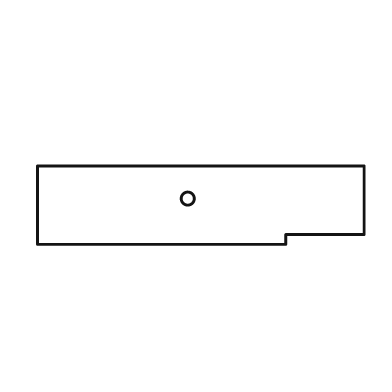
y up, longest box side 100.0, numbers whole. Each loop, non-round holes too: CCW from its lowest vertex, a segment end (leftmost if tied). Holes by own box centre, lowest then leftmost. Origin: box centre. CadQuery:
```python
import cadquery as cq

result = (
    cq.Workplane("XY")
    .moveTo(-50.0, -12.0)
    .lineTo(26.0, -12.0)
    .lineTo(26.0, -9.0)
    .lineTo(50.0, -9.0)
    .lineTo(50.0, 12.0)
    .lineTo(-50.0, 12.0)
    .close()
    .moveTo(-4.0, 2.0)
    .circle(2.0)
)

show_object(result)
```